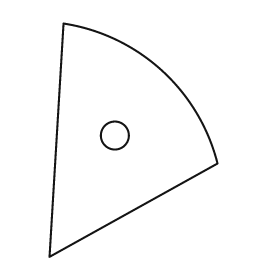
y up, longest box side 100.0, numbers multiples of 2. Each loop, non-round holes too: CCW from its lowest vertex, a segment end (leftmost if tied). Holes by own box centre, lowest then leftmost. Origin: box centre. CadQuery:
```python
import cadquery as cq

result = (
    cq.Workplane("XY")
    .moveTo(-36.0, -50.0)
    .lineTo(36.0, -10.0)
    .threePointArc((12.0, 30.0), (-30.0, 50.0))
    .close()
    .moveTo(-8.0, 2.0)
    .circle(6.0)
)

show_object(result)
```